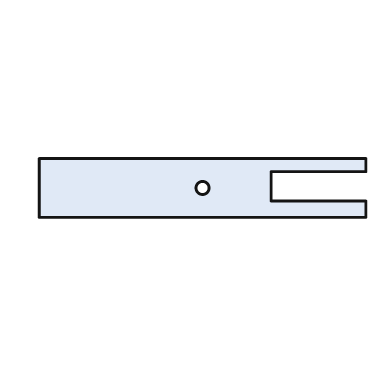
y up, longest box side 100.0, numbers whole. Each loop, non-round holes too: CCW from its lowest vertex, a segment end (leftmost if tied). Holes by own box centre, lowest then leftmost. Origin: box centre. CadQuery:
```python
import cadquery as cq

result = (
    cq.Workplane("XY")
    .moveTo(-50.0, -9.0)
    .lineTo(50.0, -9.0)
    .lineTo(50.0, -4.0)
    .lineTo(21.0, -4.0)
    .lineTo(21.0, 5.0)
    .lineTo(50.0, 5.0)
    .lineTo(50.0, 9.0)
    .lineTo(-50.0, 9.0)
    .close()
    .moveTo(0.0, 0.0)
    .circle(2.0)
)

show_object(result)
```